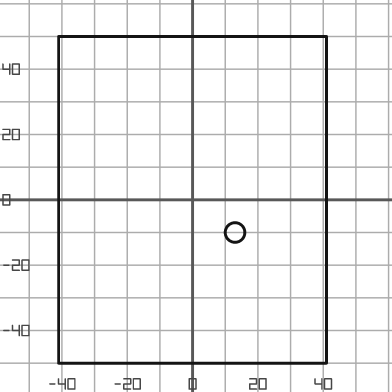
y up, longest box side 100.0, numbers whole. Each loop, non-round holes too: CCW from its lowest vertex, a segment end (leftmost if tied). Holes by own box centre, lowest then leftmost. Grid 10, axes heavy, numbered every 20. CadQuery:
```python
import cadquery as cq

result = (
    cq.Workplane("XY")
    .moveTo(-41.0, -50.0)
    .lineTo(41.0, -50.0)
    .lineTo(41.0, 50.0)
    .lineTo(-41.0, 50.0)
    .close()
    .moveTo(13.0, -10.0)
    .circle(3.0)
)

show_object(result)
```